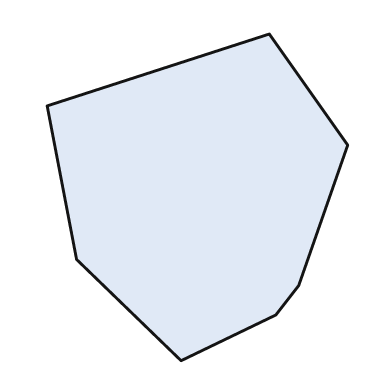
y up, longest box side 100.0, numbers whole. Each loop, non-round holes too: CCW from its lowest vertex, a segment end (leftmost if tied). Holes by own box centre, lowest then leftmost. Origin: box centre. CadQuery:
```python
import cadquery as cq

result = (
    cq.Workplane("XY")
    .moveTo(-5.0, -50.0)
    .lineTo(24.0, -36.0)
    .lineTo(31.0, -27.0)
    .lineTo(46.0, 16.0)
    .lineTo(22.0, 50.0)
    .lineTo(-46.0, 28.0)
    .lineTo(-37.0, -19.0)
    .close()
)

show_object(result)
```